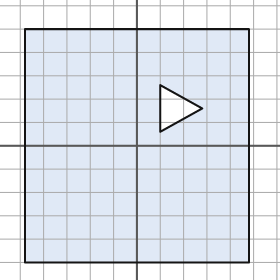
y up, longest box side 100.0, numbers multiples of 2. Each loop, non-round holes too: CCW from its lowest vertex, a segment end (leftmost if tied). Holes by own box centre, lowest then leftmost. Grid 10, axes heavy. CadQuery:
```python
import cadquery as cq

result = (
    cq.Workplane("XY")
    .moveTo(-48.0, -50.0)
    .lineTo(48.0, -50.0)
    .lineTo(48.0, 50.0)
    .lineTo(-48.0, 50.0)
    .close()
    .moveTo(10.0, 6.0)
    .lineTo(28.0, 16.0)
    .lineTo(10.0, 26.0)
    .close()
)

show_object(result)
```